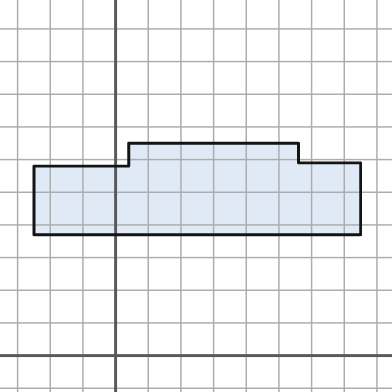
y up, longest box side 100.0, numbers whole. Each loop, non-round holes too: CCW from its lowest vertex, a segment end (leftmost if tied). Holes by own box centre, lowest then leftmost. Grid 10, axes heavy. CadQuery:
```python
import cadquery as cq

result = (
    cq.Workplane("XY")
    .moveTo(-25.0, 37.0)
    .lineTo(75.0, 37.0)
    .lineTo(75.0, 59.0)
    .lineTo(56.0, 59.0)
    .lineTo(56.0, 65.0)
    .lineTo(4.0, 65.0)
    .lineTo(4.0, 58.0)
    .lineTo(-25.0, 58.0)
    .close()
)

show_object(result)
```